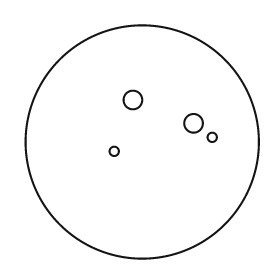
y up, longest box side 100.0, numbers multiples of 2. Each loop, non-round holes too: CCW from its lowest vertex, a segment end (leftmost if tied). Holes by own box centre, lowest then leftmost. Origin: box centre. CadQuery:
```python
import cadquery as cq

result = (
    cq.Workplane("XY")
    .moveTo(0.0, 0.0)
    .circle(50.0)
    .moveTo(-12.0, -4.0)
    .circle(2.0)
    .moveTo(30.0, 2.0)
    .circle(2.0)
    .moveTo(22.0, 8.0)
    .circle(4.0)
    .moveTo(-4.0, 18.0)
    .circle(4.0)
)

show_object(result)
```